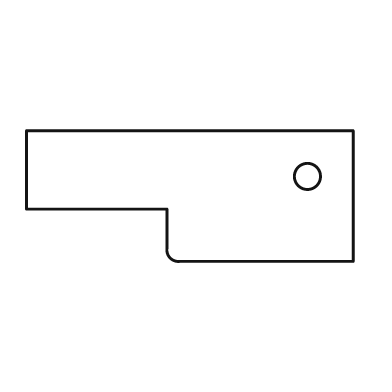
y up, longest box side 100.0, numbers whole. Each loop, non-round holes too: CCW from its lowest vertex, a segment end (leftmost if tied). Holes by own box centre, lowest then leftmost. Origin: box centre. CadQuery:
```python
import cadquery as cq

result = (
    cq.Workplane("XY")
    .moveTo(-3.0, -20.0)
    .lineTo(50.0, -20.0)
    .lineTo(50.0, 20.0)
    .lineTo(-50.0, 20.0)
    .lineTo(-50.0, -4.0)
    .lineTo(-7.0, -4.0)
    .lineTo(-7.0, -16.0)
    .threePointArc((-6.0, -19.0), (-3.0, -20.0))
    .close()
    .moveTo(36.0, 6.0)
    .circle(4.0)
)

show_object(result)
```